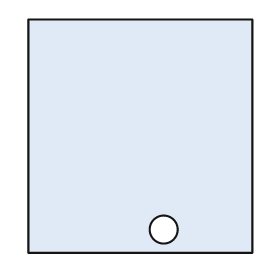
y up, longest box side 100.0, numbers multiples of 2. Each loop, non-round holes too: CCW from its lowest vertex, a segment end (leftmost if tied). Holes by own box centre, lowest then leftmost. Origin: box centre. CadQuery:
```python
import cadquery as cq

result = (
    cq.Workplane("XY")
    .moveTo(-48.0, -50.0)
    .lineTo(48.0, -50.0)
    .lineTo(48.0, 50.0)
    .lineTo(-48.0, 50.0)
    .close()
    .moveTo(10.0, -40.0)
    .circle(6.0)
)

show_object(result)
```